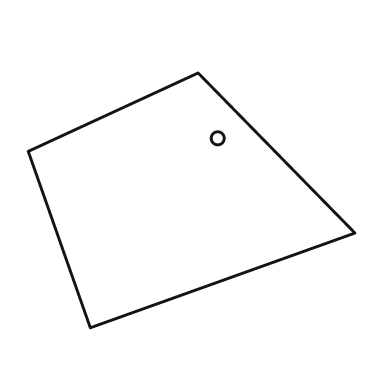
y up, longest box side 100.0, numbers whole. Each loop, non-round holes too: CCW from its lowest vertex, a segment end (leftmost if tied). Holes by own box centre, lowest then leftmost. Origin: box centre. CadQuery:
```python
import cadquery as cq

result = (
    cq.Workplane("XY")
    .moveTo(-31.0, -39.0)
    .lineTo(50.0, -10.0)
    .lineTo(2.0, 39.0)
    .lineTo(-50.0, 15.0)
    .close()
    .moveTo(8.0, 19.0)
    .circle(2.0)
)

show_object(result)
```